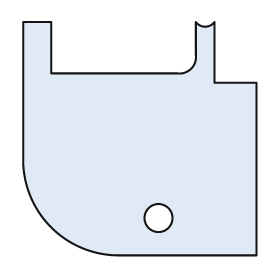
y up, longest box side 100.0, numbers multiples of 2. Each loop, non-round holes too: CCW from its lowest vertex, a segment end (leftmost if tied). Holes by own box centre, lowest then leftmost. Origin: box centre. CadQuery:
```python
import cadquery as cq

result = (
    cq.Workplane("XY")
    .moveTo(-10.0, -50.0)
    .lineTo(50.0, -50.0)
    .lineTo(50.0, 24.0)
    .lineTo(32.0, 24.0)
    .lineTo(32.0, 50.0)
    .threePointArc((28.0, 48.0), (24.0, 50.0))
    .lineTo(24.0, 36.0)
    .threePointArc((22.0, 30.0), (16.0, 28.0))
    .lineTo(-38.0, 28.0)
    .lineTo(-38.0, 50.0)
    .lineTo(-50.0, 50.0)
    .lineTo(-50.0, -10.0)
    .threePointArc((-38.0, -38.0), (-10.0, -50.0))
    .close()
    .moveTo(8.0, -34.0)
    .circle(6.0)
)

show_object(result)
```